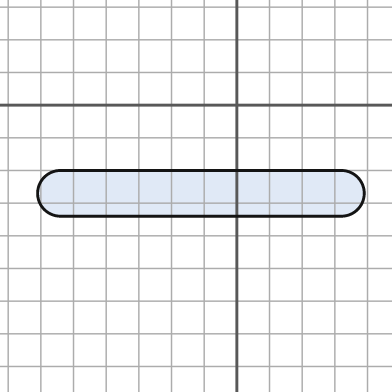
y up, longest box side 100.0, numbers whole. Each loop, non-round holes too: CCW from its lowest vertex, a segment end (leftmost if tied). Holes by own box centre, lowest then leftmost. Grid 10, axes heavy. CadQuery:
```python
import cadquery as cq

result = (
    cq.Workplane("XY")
    .moveTo(-54.0, -34.0)
    .lineTo(32.0, -34.0)
    .threePointArc((39.0, -27.0), (32.0, -20.0))
    .lineTo(-54.0, -20.0)
    .threePointArc((-61.0, -27.0), (-54.0, -34.0))
    .close()
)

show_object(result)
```